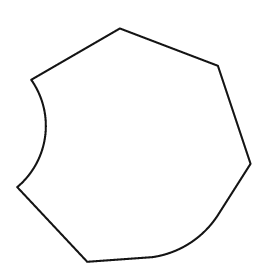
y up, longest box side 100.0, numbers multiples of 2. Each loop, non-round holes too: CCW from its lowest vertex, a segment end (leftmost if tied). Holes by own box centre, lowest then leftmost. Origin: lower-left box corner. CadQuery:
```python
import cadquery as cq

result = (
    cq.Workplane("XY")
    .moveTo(30.0, 0.0)
    .lineTo(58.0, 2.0)
    .threePointArc((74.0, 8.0), (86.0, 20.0))
    .lineTo(100.0, 42.0)
    .lineTo(86.0, 84.0)
    .lineTo(44.0, 100.0)
    .lineTo(6.0, 78.0)
    .threePointArc((12.0, 54.0), (0.0, 32.0))
    .close()
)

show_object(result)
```